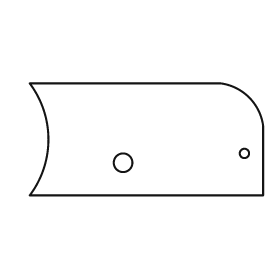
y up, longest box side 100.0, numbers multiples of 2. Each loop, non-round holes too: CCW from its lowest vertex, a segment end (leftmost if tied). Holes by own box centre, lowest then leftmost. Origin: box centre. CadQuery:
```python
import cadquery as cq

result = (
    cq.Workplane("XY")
    .moveTo(-50.0, -24.0)
    .lineTo(50.0, -24.0)
    .lineTo(50.0, 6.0)
    .threePointArc((44.0, 18.0), (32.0, 24.0))
    .lineTo(-50.0, 24.0)
    .threePointArc((-42.0, 0.0), (-50.0, -24.0))
    .close()
    .moveTo(-10.0, -10.0)
    .circle(4.0)
    .moveTo(42.0, -6.0)
    .circle(2.0)
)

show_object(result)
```